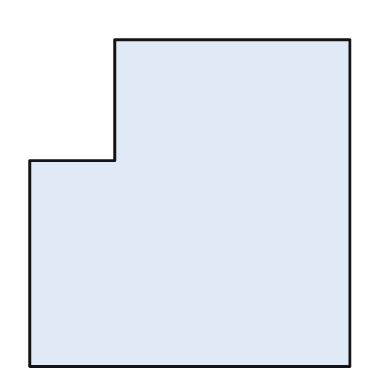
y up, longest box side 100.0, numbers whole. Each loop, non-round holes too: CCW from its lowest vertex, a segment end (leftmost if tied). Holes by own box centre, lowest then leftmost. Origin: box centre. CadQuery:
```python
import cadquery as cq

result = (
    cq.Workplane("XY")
    .moveTo(-49.0, -50.0)
    .lineTo(49.0, -50.0)
    .lineTo(49.0, 50.0)
    .lineTo(-23.0, 50.0)
    .lineTo(-23.0, 13.0)
    .lineTo(-49.0, 13.0)
    .close()
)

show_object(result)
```